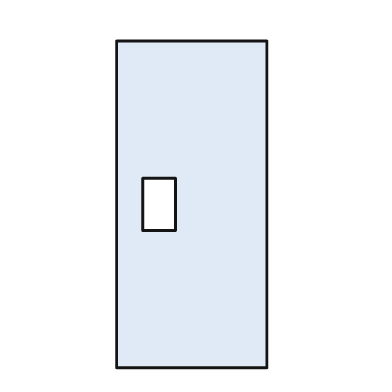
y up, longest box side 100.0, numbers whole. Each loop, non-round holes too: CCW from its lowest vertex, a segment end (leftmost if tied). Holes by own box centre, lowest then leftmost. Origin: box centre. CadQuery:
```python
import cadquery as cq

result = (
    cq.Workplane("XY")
    .moveTo(-23.0, -50.0)
    .lineTo(23.0, -50.0)
    .lineTo(23.0, 50.0)
    .lineTo(-23.0, 50.0)
    .close()
    .moveTo(-15.0, -8.0)
    .lineTo(-5.0, -8.0)
    .lineTo(-5.0, 8.0)
    .lineTo(-15.0, 8.0)
    .close()
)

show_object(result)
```